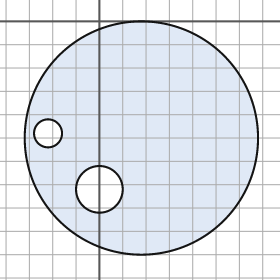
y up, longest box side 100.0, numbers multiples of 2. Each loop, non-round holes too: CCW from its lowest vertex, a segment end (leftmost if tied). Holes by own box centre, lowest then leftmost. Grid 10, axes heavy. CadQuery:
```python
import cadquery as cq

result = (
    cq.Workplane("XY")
    .moveTo(18.0, -50.0)
    .circle(50.0)
    .moveTo(0.0, -72.0)
    .circle(10.0)
    .moveTo(-22.0, -48.0)
    .circle(6.0)
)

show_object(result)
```